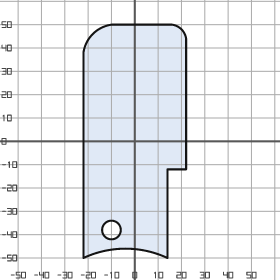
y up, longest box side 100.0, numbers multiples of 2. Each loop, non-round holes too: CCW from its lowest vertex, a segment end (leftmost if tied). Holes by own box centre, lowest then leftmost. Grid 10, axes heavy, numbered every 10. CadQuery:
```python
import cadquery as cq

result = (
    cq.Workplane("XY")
    .moveTo(-22.0, -50.0)
    .threePointArc((-4.0, -46.0), (14.0, -50.0))
    .lineTo(14.0, -12.0)
    .lineTo(22.0, -12.0)
    .lineTo(22.0, 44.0)
    .threePointArc((20.0, 48.0), (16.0, 50.0))
    .lineTo(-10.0, 50.0)
    .threePointArc((-18.0, 46.0), (-22.0, 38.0))
    .close()
    .moveTo(-10.0, -38.0)
    .circle(4.0)
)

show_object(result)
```